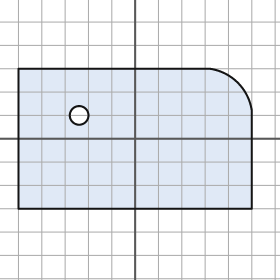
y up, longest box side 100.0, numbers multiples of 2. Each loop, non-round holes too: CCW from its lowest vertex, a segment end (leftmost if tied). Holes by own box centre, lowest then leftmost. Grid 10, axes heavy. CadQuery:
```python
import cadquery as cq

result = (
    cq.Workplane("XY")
    .moveTo(-50.0, -30.0)
    .lineTo(50.0, -30.0)
    .lineTo(50.0, 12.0)
    .threePointArc((44.0, 24.0), (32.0, 30.0))
    .lineTo(-50.0, 30.0)
    .close()
    .moveTo(-24.0, 10.0)
    .circle(4.0)
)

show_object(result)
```